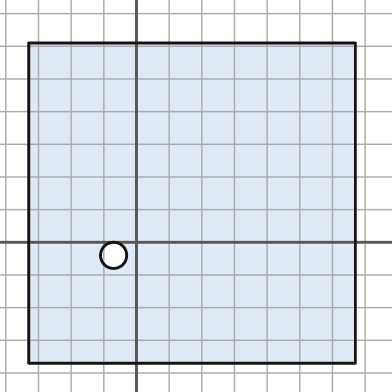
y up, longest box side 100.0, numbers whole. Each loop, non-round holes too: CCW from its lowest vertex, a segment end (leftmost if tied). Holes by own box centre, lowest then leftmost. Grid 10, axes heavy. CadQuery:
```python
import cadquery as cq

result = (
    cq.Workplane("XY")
    .moveTo(-33.0, -37.0)
    .lineTo(67.0, -37.0)
    .lineTo(67.0, 61.0)
    .lineTo(-33.0, 61.0)
    .close()
    .moveTo(-7.0, -4.0)
    .circle(4.0)
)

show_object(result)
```